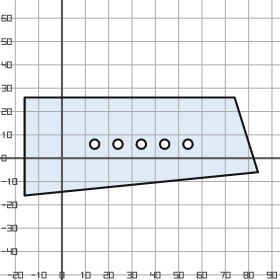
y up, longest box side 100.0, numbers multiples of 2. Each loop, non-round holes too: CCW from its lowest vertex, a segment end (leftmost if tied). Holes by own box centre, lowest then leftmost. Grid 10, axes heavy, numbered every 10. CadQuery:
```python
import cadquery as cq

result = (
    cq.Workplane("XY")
    .moveTo(-16.0, -16.0)
    .lineTo(84.0, -6.0)
    .lineTo(74.0, 26.0)
    .lineTo(-16.0, 26.0)
    .close()
    .moveTo(14.0, 6.0)
    .circle(2.0)
    .moveTo(24.0, 6.0)
    .circle(2.0)
    .moveTo(34.0, 6.0)
    .circle(2.0)
    .moveTo(44.0, 6.0)
    .circle(2.0)
    .moveTo(54.0, 6.0)
    .circle(2.0)
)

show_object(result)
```